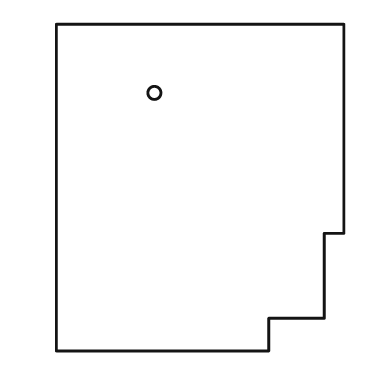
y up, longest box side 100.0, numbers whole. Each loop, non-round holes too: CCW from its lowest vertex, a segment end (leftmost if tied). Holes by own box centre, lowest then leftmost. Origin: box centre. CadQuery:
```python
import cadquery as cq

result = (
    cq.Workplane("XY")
    .moveTo(-44.0, -50.0)
    .lineTo(21.0, -50.0)
    .lineTo(21.0, -40.0)
    .lineTo(38.0, -40.0)
    .lineTo(38.0, -14.0)
    .lineTo(44.0, -14.0)
    .lineTo(44.0, 50.0)
    .lineTo(-44.0, 50.0)
    .close()
    .moveTo(-14.0, 29.0)
    .circle(2.0)
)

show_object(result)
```